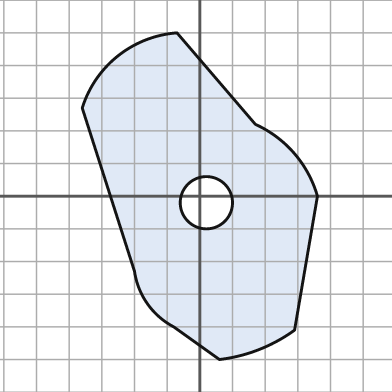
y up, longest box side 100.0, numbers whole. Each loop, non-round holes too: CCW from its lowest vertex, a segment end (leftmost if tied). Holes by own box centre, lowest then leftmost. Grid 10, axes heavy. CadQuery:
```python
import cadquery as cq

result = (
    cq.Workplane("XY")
    .moveTo(6.0, -50.0)
    .threePointArc((18.0, -47.0), (29.0, -41.0))
    .lineTo(36.0, 0.0)
    .threePointArc((29.0, 13.0), (17.0, 22.0))
    .lineTo(-7.0, 50.0)
    .threePointArc((-25.0, 43.0), (-36.0, 27.0))
    .lineTo(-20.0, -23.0)
    .threePointArc((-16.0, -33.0), (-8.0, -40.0))
    .close()
    .moveTo(2.0, -2.0)
    .circle(8.0)
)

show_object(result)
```